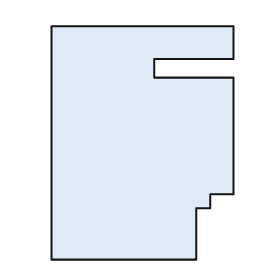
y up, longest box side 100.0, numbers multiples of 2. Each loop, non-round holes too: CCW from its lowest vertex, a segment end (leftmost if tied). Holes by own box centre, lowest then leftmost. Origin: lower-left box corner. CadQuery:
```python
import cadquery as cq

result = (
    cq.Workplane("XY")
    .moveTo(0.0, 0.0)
    .lineTo(62.0, 0.0)
    .lineTo(62.0, 22.0)
    .lineTo(68.0, 22.0)
    .lineTo(68.0, 28.0)
    .lineTo(78.0, 28.0)
    .lineTo(78.0, 78.0)
    .lineTo(44.0, 78.0)
    .lineTo(44.0, 86.0)
    .lineTo(78.0, 86.0)
    .lineTo(78.0, 100.0)
    .lineTo(0.0, 100.0)
    .close()
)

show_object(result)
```